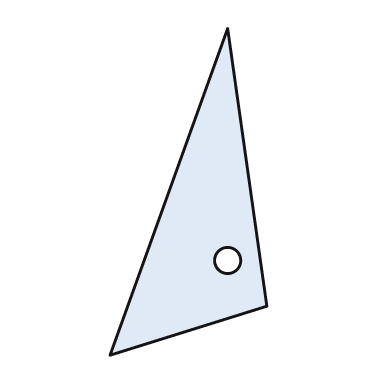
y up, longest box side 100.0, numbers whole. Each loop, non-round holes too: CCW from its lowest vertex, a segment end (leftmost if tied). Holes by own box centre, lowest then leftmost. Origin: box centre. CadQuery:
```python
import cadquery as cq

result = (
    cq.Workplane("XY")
    .moveTo(-24.0, -50.0)
    .lineTo(24.0, -35.0)
    .lineTo(12.0, 50.0)
    .close()
    .moveTo(12.0, -21.0)
    .circle(4.0)
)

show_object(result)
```